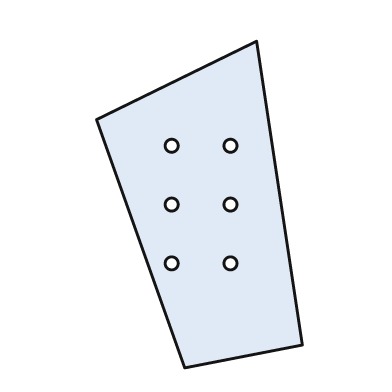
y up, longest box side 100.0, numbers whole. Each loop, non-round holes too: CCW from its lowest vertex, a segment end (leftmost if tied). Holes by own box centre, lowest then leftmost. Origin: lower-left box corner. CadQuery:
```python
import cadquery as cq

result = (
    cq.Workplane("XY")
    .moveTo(27.0, 0.0)
    .lineTo(63.0, 7.0)
    .lineTo(49.0, 100.0)
    .lineTo(0.0, 76.0)
    .close()
    .moveTo(23.0, 32.0)
    .circle(2.0)
    .moveTo(41.0, 32.0)
    .circle(2.0)
    .moveTo(23.0, 50.0)
    .circle(2.0)
    .moveTo(41.0, 50.0)
    .circle(2.0)
    .moveTo(23.0, 68.0)
    .circle(2.0)
    .moveTo(41.0, 68.0)
    .circle(2.0)
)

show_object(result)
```